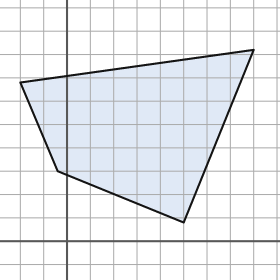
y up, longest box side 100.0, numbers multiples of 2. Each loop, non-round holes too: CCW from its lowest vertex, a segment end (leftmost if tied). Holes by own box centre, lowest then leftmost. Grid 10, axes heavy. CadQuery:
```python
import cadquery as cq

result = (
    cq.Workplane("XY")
    .moveTo(50.0, 8.0)
    .lineTo(80.0, 82.0)
    .lineTo(-20.0, 68.0)
    .lineTo(-4.0, 30.0)
    .close()
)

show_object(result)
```